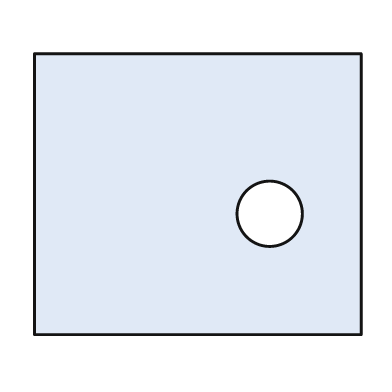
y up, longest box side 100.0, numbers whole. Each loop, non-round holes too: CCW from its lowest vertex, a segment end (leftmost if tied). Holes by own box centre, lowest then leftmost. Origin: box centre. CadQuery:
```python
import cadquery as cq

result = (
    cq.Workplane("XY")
    .moveTo(-50.0, -43.0)
    .lineTo(50.0, -43.0)
    .lineTo(50.0, 43.0)
    .lineTo(-50.0, 43.0)
    .close()
    .moveTo(22.0, -6.0)
    .circle(10.0)
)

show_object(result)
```